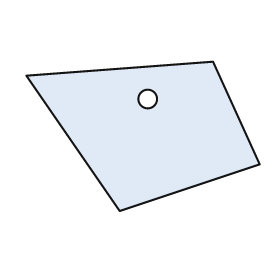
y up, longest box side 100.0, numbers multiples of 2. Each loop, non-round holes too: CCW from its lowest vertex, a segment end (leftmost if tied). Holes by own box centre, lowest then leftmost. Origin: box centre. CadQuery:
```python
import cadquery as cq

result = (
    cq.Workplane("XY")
    .moveTo(-10.0, -32.0)
    .lineTo(50.0, -12.0)
    .lineTo(30.0, 32.0)
    .lineTo(-50.0, 26.0)
    .close()
    .moveTo(2.0, 16.0)
    .circle(4.0)
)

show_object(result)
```